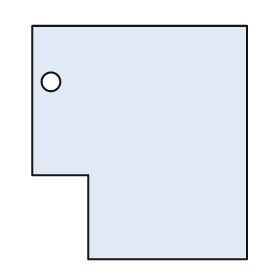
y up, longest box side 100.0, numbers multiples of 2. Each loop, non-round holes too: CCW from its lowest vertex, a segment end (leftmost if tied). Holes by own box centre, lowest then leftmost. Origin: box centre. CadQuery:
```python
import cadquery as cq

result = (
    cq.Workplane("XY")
    .moveTo(-22.0, -50.0)
    .lineTo(46.0, -50.0)
    .lineTo(46.0, 50.0)
    .lineTo(-46.0, 50.0)
    .lineTo(-46.0, -14.0)
    .lineTo(-22.0, -14.0)
    .close()
    .moveTo(-38.0, 26.0)
    .circle(4.0)
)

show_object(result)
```